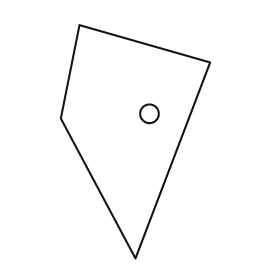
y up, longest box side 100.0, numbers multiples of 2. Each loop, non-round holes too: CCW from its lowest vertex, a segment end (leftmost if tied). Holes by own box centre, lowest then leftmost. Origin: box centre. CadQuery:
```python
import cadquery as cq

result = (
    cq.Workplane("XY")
    .moveTo(0.0, -50.0)
    .lineTo(32.0, 34.0)
    .lineTo(-24.0, 50.0)
    .lineTo(-32.0, 10.0)
    .close()
    .moveTo(6.0, 12.0)
    .circle(4.0)
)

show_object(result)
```